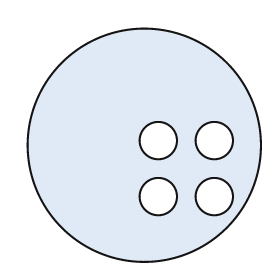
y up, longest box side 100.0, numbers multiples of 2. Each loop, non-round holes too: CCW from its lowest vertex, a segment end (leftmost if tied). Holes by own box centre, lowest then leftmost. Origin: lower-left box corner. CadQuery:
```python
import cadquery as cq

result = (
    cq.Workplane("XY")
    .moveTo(50.0, 50.0)
    .circle(50.0)
    .moveTo(56.0, 28.0)
    .circle(8.0)
    .moveTo(80.0, 28.0)
    .circle(8.0)
    .moveTo(56.0, 52.0)
    .circle(8.0)
    .moveTo(80.0, 52.0)
    .circle(8.0)
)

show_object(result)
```